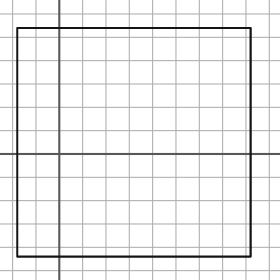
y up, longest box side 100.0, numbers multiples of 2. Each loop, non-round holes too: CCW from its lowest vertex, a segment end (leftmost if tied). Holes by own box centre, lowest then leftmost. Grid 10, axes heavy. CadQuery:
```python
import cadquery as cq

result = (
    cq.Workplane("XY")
    .moveTo(-18.0, -44.0)
    .lineTo(82.0, -44.0)
    .lineTo(82.0, 54.0)
    .lineTo(-18.0, 54.0)
    .close()
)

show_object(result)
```